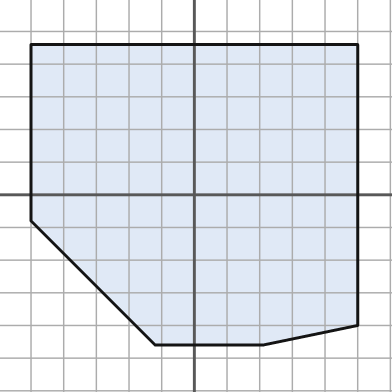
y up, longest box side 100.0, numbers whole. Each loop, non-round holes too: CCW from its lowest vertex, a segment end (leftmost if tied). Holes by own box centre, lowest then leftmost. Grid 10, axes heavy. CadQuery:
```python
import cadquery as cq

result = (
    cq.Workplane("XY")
    .moveTo(-12.0, -46.0)
    .lineTo(21.0, -46.0)
    .lineTo(50.0, -40.0)
    .lineTo(50.0, 46.0)
    .lineTo(-50.0, 46.0)
    .lineTo(-50.0, -8.0)
    .close()
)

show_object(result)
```